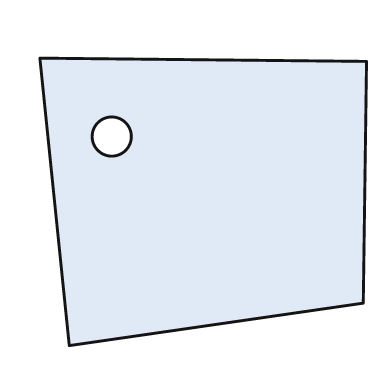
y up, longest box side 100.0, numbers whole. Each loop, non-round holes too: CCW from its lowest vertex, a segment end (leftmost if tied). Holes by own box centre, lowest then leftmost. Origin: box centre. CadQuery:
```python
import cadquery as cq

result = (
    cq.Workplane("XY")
    .moveTo(-41.0, -44.0)
    .lineTo(49.0, -31.0)
    .lineTo(50.0, 43.0)
    .lineTo(-50.0, 44.0)
    .close()
    .moveTo(-28.0, 20.0)
    .circle(6.0)
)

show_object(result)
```